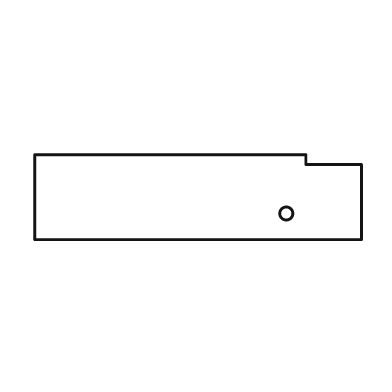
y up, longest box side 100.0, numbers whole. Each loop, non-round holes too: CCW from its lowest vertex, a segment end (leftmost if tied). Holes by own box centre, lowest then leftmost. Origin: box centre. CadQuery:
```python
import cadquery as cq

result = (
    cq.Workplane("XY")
    .moveTo(-50.0, -13.0)
    .lineTo(50.0, -13.0)
    .lineTo(50.0, 10.0)
    .lineTo(33.0, 10.0)
    .lineTo(33.0, 13.0)
    .lineTo(-50.0, 13.0)
    .close()
    .moveTo(27.0, -5.0)
    .circle(2.0)
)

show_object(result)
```